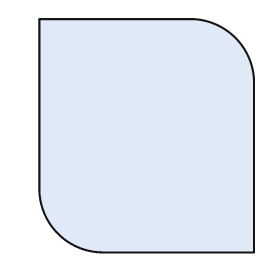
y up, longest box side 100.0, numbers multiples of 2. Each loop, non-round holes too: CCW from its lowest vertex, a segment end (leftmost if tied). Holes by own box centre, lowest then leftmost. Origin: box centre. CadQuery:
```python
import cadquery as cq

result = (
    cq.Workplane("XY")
    .moveTo(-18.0, -50.0)
    .lineTo(46.0, -50.0)
    .lineTo(46.0, 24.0)
    .threePointArc((38.0, 42.0), (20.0, 50.0))
    .lineTo(-46.0, 50.0)
    .lineTo(-46.0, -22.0)
    .threePointArc((-38.0, -42.0), (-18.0, -50.0))
    .close()
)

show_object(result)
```